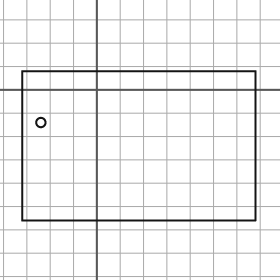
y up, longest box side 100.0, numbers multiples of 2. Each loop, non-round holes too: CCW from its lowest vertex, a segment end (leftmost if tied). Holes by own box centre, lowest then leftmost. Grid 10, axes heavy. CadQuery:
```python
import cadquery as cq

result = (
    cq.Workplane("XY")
    .moveTo(-32.0, -56.0)
    .lineTo(68.0, -56.0)
    .lineTo(68.0, 8.0)
    .lineTo(-32.0, 8.0)
    .close()
    .moveTo(-24.0, -14.0)
    .circle(2.0)
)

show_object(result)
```